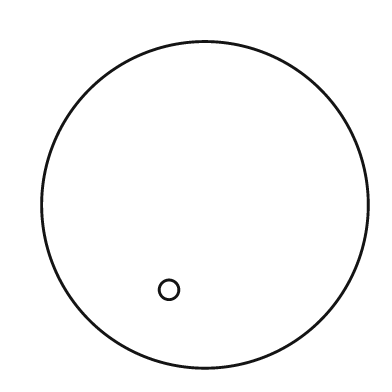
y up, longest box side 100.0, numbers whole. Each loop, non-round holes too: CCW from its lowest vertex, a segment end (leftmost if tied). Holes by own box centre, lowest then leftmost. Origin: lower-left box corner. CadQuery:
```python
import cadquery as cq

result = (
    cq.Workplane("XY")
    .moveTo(50.0, 50.0)
    .circle(50.0)
    .moveTo(39.0, 24.0)
    .circle(3.0)
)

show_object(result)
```